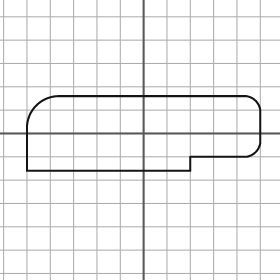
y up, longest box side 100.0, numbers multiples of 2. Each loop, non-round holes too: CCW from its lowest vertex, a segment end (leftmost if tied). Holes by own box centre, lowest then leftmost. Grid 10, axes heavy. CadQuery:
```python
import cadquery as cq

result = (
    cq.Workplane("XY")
    .moveTo(-50.0, -16.0)
    .lineTo(20.0, -16.0)
    .lineTo(20.0, -10.0)
    .lineTo(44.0, -10.0)
    .threePointArc((48.0, -8.0), (50.0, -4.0))
    .lineTo(50.0, 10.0)
    .threePointArc((48.0, 14.0), (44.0, 16.0))
    .lineTo(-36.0, 16.0)
    .threePointArc((-46.0, 12.0), (-50.0, 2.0))
    .close()
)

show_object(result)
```